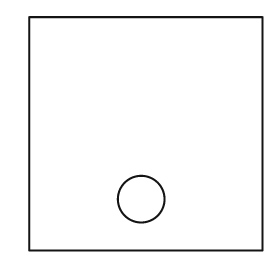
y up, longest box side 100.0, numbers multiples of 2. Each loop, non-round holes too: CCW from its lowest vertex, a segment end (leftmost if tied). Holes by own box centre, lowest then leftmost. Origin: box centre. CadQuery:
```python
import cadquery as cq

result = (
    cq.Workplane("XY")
    .moveTo(-50.0, -50.0)
    .lineTo(50.0, -50.0)
    .lineTo(50.0, 50.0)
    .lineTo(-50.0, 50.0)
    .close()
    .moveTo(-2.0, -28.0)
    .circle(10.0)
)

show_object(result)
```